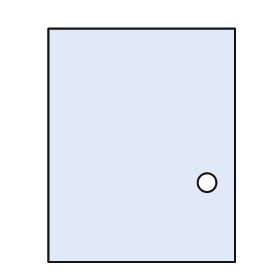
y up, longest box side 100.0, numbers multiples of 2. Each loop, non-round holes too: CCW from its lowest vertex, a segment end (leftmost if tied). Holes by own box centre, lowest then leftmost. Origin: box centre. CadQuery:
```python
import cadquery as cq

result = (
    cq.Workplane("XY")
    .moveTo(-40.0, -50.0)
    .lineTo(40.0, -50.0)
    .lineTo(40.0, 50.0)
    .lineTo(-40.0, 50.0)
    .close()
    .moveTo(28.0, -16.0)
    .circle(4.0)
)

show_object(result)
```